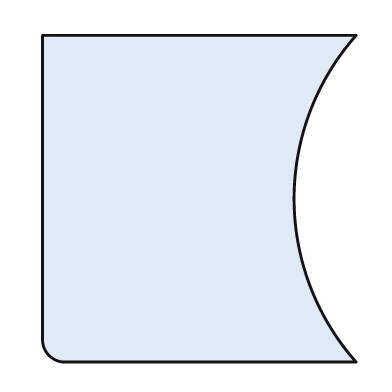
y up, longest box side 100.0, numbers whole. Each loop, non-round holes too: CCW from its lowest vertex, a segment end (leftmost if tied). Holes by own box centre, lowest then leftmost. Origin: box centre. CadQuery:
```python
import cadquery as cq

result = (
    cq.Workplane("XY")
    .moveTo(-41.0, -50.0)
    .lineTo(48.0, -50.0)
    .threePointArc((29.0, 0.0), (48.0, 50.0))
    .lineTo(-48.0, 50.0)
    .lineTo(-48.0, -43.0)
    .threePointArc((-46.0, -48.0), (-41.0, -50.0))
    .close()
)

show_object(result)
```